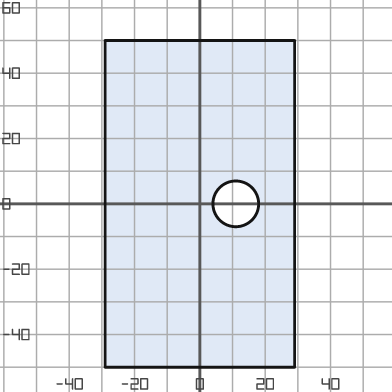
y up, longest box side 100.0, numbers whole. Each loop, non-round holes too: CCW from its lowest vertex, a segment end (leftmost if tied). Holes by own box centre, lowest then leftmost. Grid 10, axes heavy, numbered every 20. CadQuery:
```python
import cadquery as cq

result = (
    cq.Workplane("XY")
    .moveTo(-29.0, -50.0)
    .lineTo(29.0, -50.0)
    .lineTo(29.0, 50.0)
    .lineTo(-29.0, 50.0)
    .close()
    .moveTo(11.0, 0.0)
    .circle(7.0)
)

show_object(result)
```